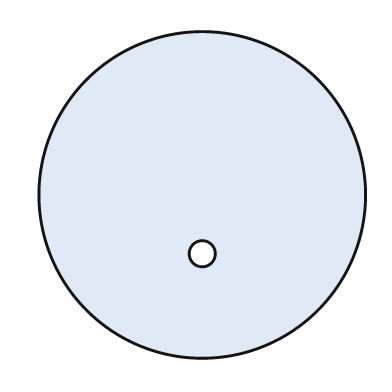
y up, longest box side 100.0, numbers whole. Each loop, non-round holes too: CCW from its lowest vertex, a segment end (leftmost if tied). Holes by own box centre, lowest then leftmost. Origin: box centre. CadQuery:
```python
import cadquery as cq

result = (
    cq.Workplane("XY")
    .moveTo(0.0, 0.0)
    .circle(50.0)
    .moveTo(0.0, -18.0)
    .circle(4.0)
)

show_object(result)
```